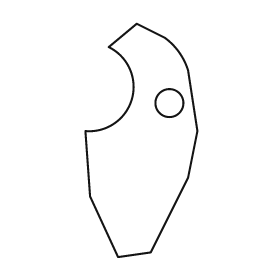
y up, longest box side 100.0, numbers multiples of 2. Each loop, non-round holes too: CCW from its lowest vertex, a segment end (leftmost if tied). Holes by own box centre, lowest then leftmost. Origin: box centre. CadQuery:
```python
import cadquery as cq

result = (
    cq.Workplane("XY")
    .moveTo(-10.0, -50.0)
    .lineTo(4.0, -48.0)
    .lineTo(20.0, -16.0)
    .lineTo(24.0, 4.0)
    .lineTo(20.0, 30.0)
    .threePointArc((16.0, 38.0), (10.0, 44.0))
    .lineTo(-2.0, 50.0)
    .lineTo(-14.0, 40.0)
    .threePointArc((-4.0, 18.0), (-24.0, 4.0))
    .lineTo(-22.0, -24.0)
    .close()
    .moveTo(12.0, 16.0)
    .circle(6.0)
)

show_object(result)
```